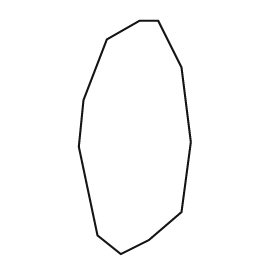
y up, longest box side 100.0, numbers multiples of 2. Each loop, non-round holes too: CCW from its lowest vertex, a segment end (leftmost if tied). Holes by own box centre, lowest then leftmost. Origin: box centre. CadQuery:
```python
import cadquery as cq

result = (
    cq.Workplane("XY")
    .moveTo(-6.0, -50.0)
    .lineTo(6.0, -44.0)
    .lineTo(20.0, -32.0)
    .lineTo(24.0, -2.0)
    .lineTo(20.0, 30.0)
    .lineTo(10.0, 50.0)
    .lineTo(2.0, 50.0)
    .lineTo(-12.0, 42.0)
    .lineTo(-22.0, 16.0)
    .lineTo(-24.0, -4.0)
    .lineTo(-16.0, -42.0)
    .close()
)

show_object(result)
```